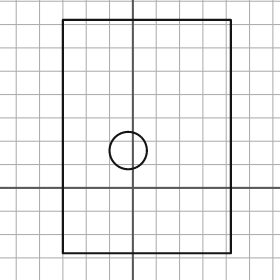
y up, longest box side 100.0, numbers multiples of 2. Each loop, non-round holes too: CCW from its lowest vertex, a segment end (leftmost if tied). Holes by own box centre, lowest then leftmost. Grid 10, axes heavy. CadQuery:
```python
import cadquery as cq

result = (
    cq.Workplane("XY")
    .moveTo(-30.0, -28.0)
    .lineTo(42.0, -28.0)
    .lineTo(42.0, 72.0)
    .lineTo(-30.0, 72.0)
    .close()
    .moveTo(-2.0, 16.0)
    .circle(8.0)
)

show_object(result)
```